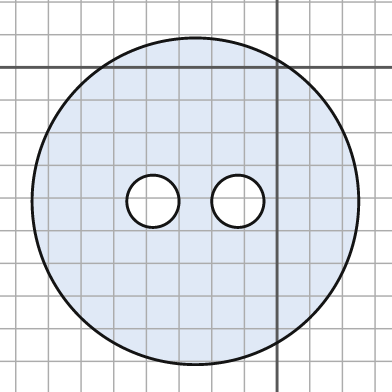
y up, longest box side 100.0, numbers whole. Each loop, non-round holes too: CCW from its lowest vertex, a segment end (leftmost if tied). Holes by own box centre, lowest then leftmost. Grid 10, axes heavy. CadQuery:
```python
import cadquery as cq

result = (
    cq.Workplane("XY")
    .moveTo(-25.0, -41.0)
    .circle(50.0)
    .moveTo(-38.0, -41.0)
    .circle(8.0)
    .moveTo(-12.0, -41.0)
    .circle(8.0)
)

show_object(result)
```